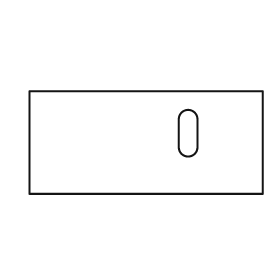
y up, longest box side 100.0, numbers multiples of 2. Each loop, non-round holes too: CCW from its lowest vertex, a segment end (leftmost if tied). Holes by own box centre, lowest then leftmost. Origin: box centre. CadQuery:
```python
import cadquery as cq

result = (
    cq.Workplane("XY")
    .moveTo(-50.0, -22.0)
    .lineTo(50.0, -22.0)
    .lineTo(50.0, 22.0)
    .lineTo(-50.0, 22.0)
    .close()
    .moveTo(14.0, -2.0)
    .threePointArc((18.0, -6.0), (22.0, -2.0))
    .lineTo(22.0, 10.0)
    .threePointArc((18.0, 14.0), (14.0, 10.0))
    .close()
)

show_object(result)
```